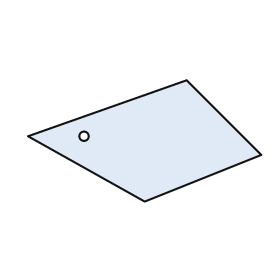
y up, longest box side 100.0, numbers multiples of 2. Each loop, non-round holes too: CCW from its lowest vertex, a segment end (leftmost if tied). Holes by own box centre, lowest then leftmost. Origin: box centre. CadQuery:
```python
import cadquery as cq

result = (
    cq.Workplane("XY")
    .moveTo(0.0, -26.0)
    .lineTo(50.0, -6.0)
    .lineTo(18.0, 26.0)
    .lineTo(-50.0, 2.0)
    .close()
    .moveTo(-26.0, 2.0)
    .circle(2.0)
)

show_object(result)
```